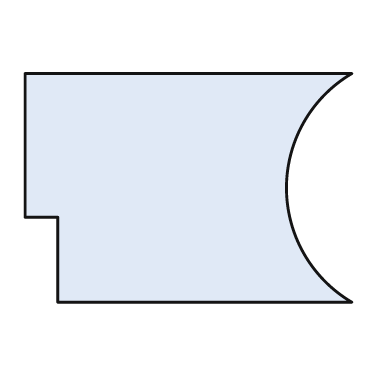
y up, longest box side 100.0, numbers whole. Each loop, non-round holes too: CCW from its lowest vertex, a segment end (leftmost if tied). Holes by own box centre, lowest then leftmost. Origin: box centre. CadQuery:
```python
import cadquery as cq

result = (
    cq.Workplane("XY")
    .moveTo(-40.0, -35.0)
    .lineTo(50.0, -35.0)
    .threePointArc((30.0, 0.0), (50.0, 35.0))
    .lineTo(-50.0, 35.0)
    .lineTo(-50.0, -9.0)
    .lineTo(-40.0, -9.0)
    .close()
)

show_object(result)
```